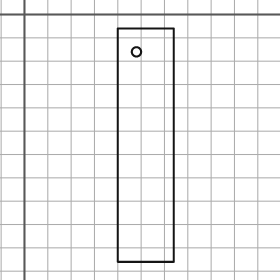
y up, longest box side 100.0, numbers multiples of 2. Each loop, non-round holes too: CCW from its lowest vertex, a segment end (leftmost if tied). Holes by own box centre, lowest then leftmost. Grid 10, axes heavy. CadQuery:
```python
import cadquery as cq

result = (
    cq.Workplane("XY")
    .moveTo(40.0, -106.0)
    .lineTo(64.0, -106.0)
    .lineTo(64.0, -6.0)
    .lineTo(40.0, -6.0)
    .close()
    .moveTo(48.0, -16.0)
    .circle(2.0)
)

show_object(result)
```